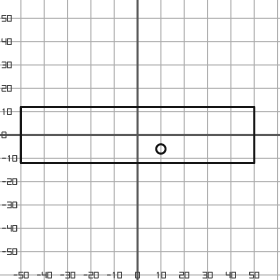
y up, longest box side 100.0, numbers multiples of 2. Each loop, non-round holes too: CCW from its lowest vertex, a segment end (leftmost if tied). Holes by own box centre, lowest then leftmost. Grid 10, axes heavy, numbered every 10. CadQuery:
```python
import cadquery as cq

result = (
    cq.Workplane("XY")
    .moveTo(-50.0, -12.0)
    .lineTo(50.0, -12.0)
    .lineTo(50.0, 12.0)
    .lineTo(-50.0, 12.0)
    .close()
    .moveTo(10.0, -6.0)
    .circle(2.0)
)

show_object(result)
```